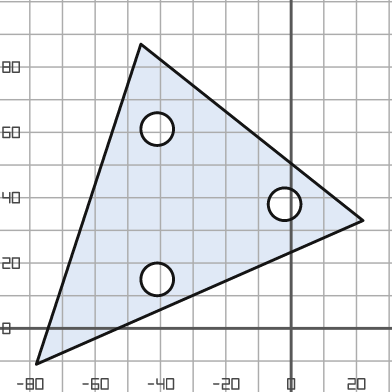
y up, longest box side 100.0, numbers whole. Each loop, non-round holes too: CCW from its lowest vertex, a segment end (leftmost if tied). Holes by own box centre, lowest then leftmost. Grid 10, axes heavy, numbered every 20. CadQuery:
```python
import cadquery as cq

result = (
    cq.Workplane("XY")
    .moveTo(-78.0, -11.0)
    .lineTo(22.0, 33.0)
    .lineTo(-46.0, 87.0)
    .close()
    .moveTo(-41.0, 15.0)
    .circle(5.0)
    .moveTo(-2.0, 38.0)
    .circle(5.0)
    .moveTo(-41.0, 61.0)
    .circle(5.0)
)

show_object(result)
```